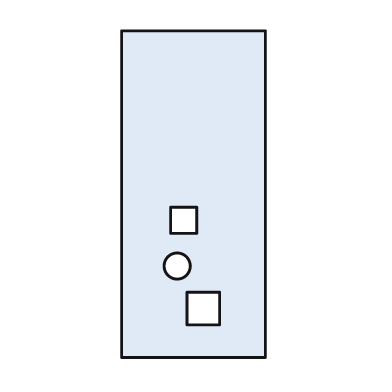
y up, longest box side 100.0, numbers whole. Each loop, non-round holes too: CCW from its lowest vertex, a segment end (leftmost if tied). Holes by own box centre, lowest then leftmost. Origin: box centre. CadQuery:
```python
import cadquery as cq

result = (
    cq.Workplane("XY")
    .moveTo(-22.0, -50.0)
    .lineTo(22.0, -50.0)
    .lineTo(22.0, 50.0)
    .lineTo(-22.0, 50.0)
    .close()
    .moveTo(-2.0, -40.0)
    .lineTo(8.0, -40.0)
    .lineTo(8.0, -30.0)
    .lineTo(-2.0, -30.0)
    .close()
    .moveTo(-5.0, -22.0)
    .circle(4.0)
    .moveTo(-7.0, -12.0)
    .lineTo(1.0, -12.0)
    .lineTo(1.0, -4.0)
    .lineTo(-7.0, -4.0)
    .close()
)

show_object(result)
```